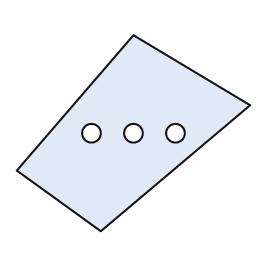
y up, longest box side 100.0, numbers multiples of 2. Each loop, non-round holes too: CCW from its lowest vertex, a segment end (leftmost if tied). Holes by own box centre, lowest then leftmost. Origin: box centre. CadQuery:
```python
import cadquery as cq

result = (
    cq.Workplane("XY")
    .moveTo(-14.0, -42.0)
    .lineTo(50.0, 12.0)
    .lineTo(0.0, 42.0)
    .lineTo(-50.0, -16.0)
    .close()
    .moveTo(-18.0, 0.0)
    .circle(4.0)
    .moveTo(0.0, 0.0)
    .circle(4.0)
    .moveTo(18.0, 0.0)
    .circle(4.0)
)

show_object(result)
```